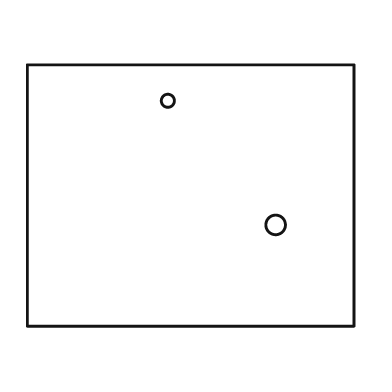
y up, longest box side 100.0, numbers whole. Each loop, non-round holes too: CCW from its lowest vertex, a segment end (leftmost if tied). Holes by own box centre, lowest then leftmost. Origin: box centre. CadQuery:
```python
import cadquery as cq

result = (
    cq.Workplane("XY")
    .moveTo(-50.0, -40.0)
    .lineTo(50.0, -40.0)
    .lineTo(50.0, 40.0)
    .lineTo(-50.0, 40.0)
    .close()
    .moveTo(26.0, -9.0)
    .circle(3.0)
    .moveTo(-7.0, 29.0)
    .circle(2.0)
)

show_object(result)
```